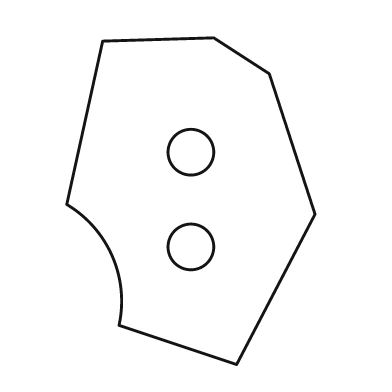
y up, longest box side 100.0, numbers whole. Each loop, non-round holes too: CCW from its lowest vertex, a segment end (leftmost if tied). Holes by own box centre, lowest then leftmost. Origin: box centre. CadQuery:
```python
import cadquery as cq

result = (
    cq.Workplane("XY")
    .moveTo(14.0, -50.0)
    .lineTo(38.0, -4.0)
    .lineTo(24.0, 39.0)
    .lineTo(7.0, 50.0)
    .lineTo(-27.0, 49.0)
    .lineTo(-38.0, -1.0)
    .threePointArc((-24.0, -17.0), (-22.0, -38.0))
    .close()
    .moveTo(0.0, -14.0)
    .circle(7.0)
    .moveTo(0.0, 15.0)
    .circle(7.0)
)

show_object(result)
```